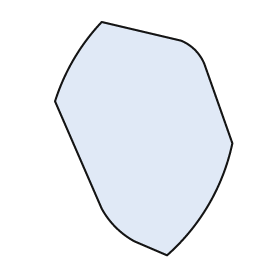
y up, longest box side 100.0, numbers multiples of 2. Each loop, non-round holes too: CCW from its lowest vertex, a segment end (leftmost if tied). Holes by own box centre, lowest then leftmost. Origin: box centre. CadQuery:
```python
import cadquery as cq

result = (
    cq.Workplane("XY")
    .moveTo(10.0, -50.0)
    .threePointArc((28.0, -28.0), (38.0, -2.0))
    .lineTo(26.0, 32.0)
    .threePointArc((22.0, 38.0), (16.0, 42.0))
    .lineTo(-18.0, 50.0)
    .threePointArc((-30.0, 34.0), (-38.0, 16.0))
    .lineTo(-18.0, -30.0)
    .threePointArc((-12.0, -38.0), (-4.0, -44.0))
    .close()
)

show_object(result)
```